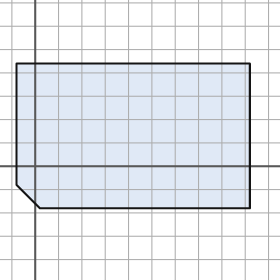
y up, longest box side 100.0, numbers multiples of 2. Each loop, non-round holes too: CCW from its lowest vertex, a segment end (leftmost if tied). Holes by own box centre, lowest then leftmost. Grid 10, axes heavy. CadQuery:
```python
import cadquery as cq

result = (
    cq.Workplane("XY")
    .moveTo(2.0, -18.0)
    .lineTo(92.0, -18.0)
    .lineTo(92.0, 44.0)
    .lineTo(-8.0, 44.0)
    .lineTo(-8.0, -8.0)
    .close()
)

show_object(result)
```